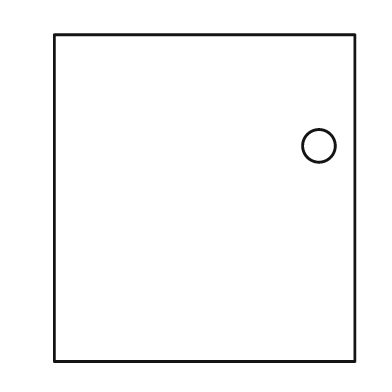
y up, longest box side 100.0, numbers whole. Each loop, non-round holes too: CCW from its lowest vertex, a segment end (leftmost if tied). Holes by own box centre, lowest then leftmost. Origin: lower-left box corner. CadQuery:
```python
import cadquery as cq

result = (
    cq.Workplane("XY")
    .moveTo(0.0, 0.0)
    .lineTo(92.0, 0.0)
    .lineTo(92.0, 100.0)
    .lineTo(0.0, 100.0)
    .close()
    .moveTo(81.0, 66.0)
    .circle(5.0)
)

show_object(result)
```